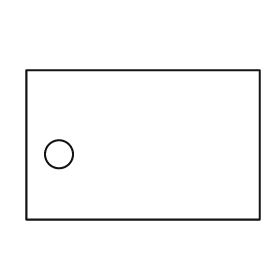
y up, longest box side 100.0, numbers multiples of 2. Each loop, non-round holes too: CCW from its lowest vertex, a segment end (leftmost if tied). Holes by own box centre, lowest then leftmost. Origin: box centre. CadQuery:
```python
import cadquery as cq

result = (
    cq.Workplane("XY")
    .moveTo(-50.0, -32.0)
    .lineTo(50.0, -32.0)
    .lineTo(50.0, 32.0)
    .lineTo(-50.0, 32.0)
    .close()
    .moveTo(-36.0, -4.0)
    .circle(6.0)
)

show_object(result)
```